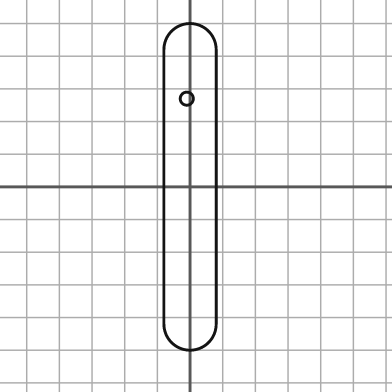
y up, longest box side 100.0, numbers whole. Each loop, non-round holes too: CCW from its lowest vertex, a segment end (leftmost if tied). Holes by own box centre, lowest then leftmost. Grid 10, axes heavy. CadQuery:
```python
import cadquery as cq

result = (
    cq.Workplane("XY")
    .moveTo(-8.0, -42.0)
    .threePointArc((0.0, -50.0), (8.0, -42.0))
    .lineTo(8.0, 42.0)
    .threePointArc((0.0, 50.0), (-8.0, 42.0))
    .close()
    .moveTo(-1.0, 27.0)
    .circle(2.0)
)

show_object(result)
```